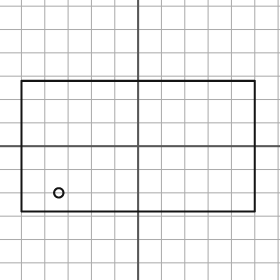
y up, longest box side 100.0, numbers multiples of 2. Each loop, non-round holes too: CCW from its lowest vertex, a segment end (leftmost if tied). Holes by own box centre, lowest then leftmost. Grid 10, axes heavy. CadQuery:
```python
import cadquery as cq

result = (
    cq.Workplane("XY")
    .moveTo(-50.0, -28.0)
    .lineTo(50.0, -28.0)
    .lineTo(50.0, 28.0)
    .lineTo(-50.0, 28.0)
    .close()
    .moveTo(-34.0, -20.0)
    .circle(2.0)
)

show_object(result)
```